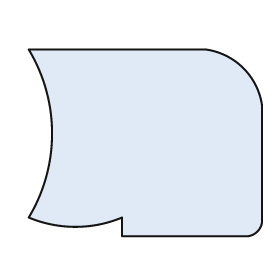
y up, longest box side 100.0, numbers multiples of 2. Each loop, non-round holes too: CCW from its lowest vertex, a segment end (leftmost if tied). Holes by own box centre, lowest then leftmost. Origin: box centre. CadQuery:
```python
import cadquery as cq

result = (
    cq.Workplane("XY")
    .moveTo(-10.0, -40.0)
    .lineTo(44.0, -40.0)
    .threePointArc((48.0, -38.0), (50.0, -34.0))
    .lineTo(50.0, 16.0)
    .threePointArc((42.0, 32.0), (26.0, 40.0))
    .lineTo(-50.0, 40.0)
    .threePointArc((-40.0, 4.0), (-50.0, -32.0))
    .threePointArc((-30.0, -36.0), (-10.0, -32.0))
    .close()
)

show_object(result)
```